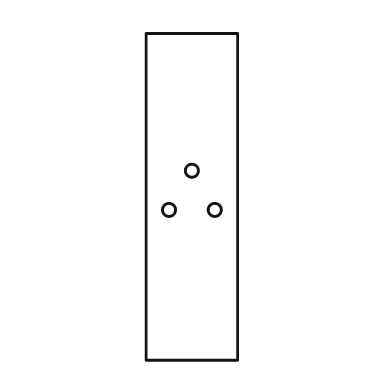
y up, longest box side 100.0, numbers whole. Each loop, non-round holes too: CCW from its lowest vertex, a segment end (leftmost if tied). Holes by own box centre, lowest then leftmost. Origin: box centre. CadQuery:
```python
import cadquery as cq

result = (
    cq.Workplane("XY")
    .moveTo(-14.0, -50.0)
    .lineTo(14.0, -50.0)
    .lineTo(14.0, 50.0)
    .lineTo(-14.0, 50.0)
    .close()
    .moveTo(-7.0, -4.0)
    .circle(2.0)
    .moveTo(7.0, -4.0)
    .circle(2.0)
    .moveTo(0.0, 8.0)
    .circle(2.0)
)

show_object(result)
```